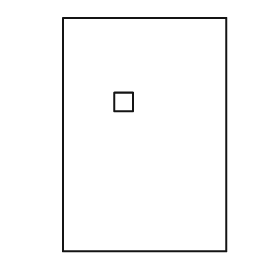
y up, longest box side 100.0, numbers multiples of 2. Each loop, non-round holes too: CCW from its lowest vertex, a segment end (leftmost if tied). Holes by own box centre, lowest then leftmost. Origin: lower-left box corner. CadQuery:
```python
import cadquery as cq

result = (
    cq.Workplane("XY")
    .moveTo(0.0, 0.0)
    .lineTo(70.0, 0.0)
    .lineTo(70.0, 100.0)
    .lineTo(0.0, 100.0)
    .close()
    .moveTo(22.0, 60.0)
    .lineTo(30.0, 60.0)
    .lineTo(30.0, 68.0)
    .lineTo(22.0, 68.0)
    .close()
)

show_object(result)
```